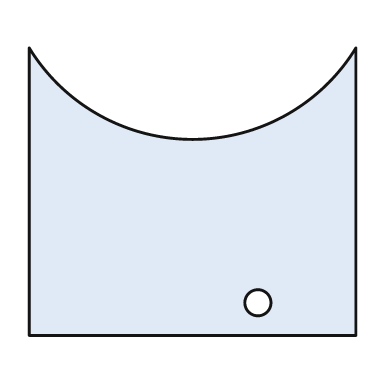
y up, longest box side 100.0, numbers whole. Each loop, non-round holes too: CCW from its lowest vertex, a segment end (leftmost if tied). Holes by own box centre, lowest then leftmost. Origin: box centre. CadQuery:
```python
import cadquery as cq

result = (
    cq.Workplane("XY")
    .moveTo(-50.0, -44.0)
    .lineTo(50.0, -44.0)
    .lineTo(50.0, 44.0)
    .threePointArc((0.0, 16.0), (-50.0, 44.0))
    .close()
    .moveTo(20.0, -34.0)
    .circle(4.0)
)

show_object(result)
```